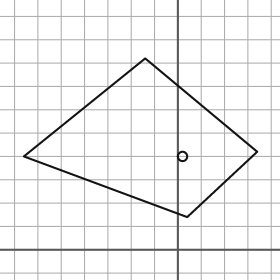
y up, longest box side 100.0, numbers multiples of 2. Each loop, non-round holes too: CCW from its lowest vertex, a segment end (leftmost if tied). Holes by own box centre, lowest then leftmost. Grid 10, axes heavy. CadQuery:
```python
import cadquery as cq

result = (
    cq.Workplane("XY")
    .moveTo(4.0, 14.0)
    .lineTo(34.0, 42.0)
    .lineTo(-14.0, 82.0)
    .lineTo(-66.0, 40.0)
    .close()
    .moveTo(2.0, 40.0)
    .circle(2.0)
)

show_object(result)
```